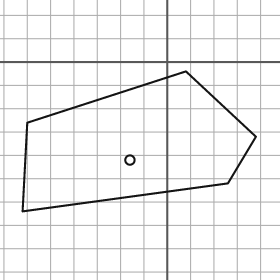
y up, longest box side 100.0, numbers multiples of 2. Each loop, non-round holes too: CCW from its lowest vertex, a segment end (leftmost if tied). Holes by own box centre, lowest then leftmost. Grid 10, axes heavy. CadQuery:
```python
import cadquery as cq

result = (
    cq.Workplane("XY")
    .moveTo(-62.0, -64.0)
    .lineTo(26.0, -52.0)
    .lineTo(38.0, -32.0)
    .lineTo(8.0, -4.0)
    .lineTo(-60.0, -26.0)
    .close()
    .moveTo(-16.0, -42.0)
    .circle(2.0)
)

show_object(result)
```